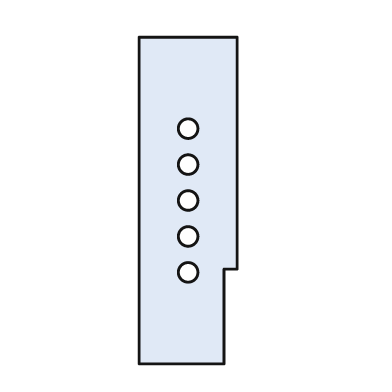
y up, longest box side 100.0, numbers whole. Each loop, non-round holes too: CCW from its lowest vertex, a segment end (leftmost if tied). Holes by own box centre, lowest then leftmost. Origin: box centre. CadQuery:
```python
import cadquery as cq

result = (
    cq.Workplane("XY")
    .moveTo(-15.0, -50.0)
    .lineTo(11.0, -50.0)
    .lineTo(11.0, -21.0)
    .lineTo(15.0, -21.0)
    .lineTo(15.0, 50.0)
    .lineTo(-15.0, 50.0)
    .close()
    .moveTo(0.0, -22.0)
    .circle(3.0)
    .moveTo(0.0, -11.0)
    .circle(3.0)
    .moveTo(0.0, 0.0)
    .circle(3.0)
    .moveTo(0.0, 11.0)
    .circle(3.0)
    .moveTo(0.0, 22.0)
    .circle(3.0)
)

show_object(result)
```